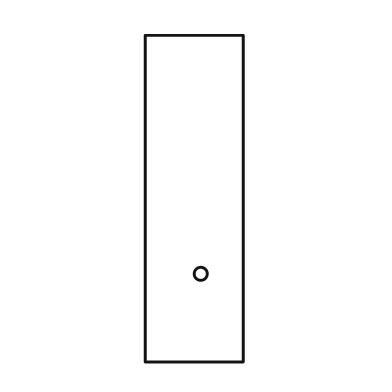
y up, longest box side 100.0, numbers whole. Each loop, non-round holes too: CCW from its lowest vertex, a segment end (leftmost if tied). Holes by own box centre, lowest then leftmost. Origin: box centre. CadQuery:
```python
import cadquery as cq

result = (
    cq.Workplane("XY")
    .moveTo(-15.0, -50.0)
    .lineTo(15.0, -50.0)
    .lineTo(15.0, 50.0)
    .lineTo(-15.0, 50.0)
    .close()
    .moveTo(2.0, -23.0)
    .circle(2.0)
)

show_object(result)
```